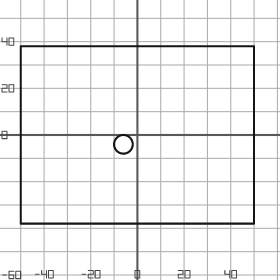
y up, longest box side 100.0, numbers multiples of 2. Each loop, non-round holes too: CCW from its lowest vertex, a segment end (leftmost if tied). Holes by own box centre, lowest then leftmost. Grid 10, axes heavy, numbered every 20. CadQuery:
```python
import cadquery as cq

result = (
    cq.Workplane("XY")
    .moveTo(-50.0, -38.0)
    .lineTo(50.0, -38.0)
    .lineTo(50.0, 38.0)
    .lineTo(-50.0, 38.0)
    .close()
    .moveTo(-6.0, -4.0)
    .circle(4.0)
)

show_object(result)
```